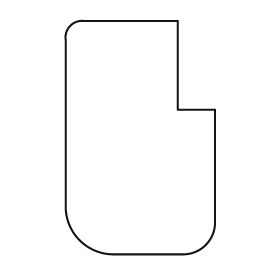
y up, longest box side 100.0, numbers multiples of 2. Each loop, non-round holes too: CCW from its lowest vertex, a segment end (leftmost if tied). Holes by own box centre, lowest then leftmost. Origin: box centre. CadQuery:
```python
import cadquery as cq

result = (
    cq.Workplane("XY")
    .moveTo(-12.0, -50.0)
    .lineTo(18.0, -50.0)
    .threePointArc((28.0, -46.0), (32.0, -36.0))
    .lineTo(32.0, 12.0)
    .lineTo(16.0, 12.0)
    .lineTo(16.0, 50.0)
    .lineTo(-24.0, 50.0)
    .threePointArc((-30.0, 48.0), (-32.0, 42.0))
    .lineTo(-32.0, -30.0)
    .threePointArc((-26.0, -44.0), (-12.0, -50.0))
    .close()
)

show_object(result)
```